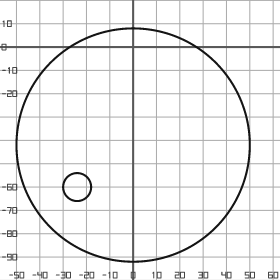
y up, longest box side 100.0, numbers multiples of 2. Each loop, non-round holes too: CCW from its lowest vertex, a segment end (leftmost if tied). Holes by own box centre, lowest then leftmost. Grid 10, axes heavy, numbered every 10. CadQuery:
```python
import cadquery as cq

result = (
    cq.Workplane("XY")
    .moveTo(0.0, -42.0)
    .circle(50.0)
    .moveTo(-24.0, -60.0)
    .circle(6.0)
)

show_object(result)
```